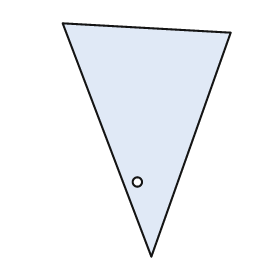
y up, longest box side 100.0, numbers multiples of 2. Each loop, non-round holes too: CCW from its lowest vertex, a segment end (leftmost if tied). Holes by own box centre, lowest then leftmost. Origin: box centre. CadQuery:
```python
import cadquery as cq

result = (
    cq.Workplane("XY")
    .moveTo(2.0, -50.0)
    .lineTo(36.0, 46.0)
    .lineTo(-36.0, 50.0)
    .close()
    .moveTo(-4.0, -18.0)
    .circle(2.0)
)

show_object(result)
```